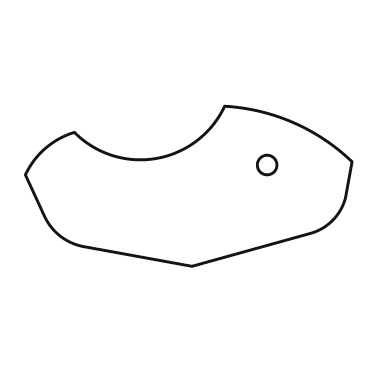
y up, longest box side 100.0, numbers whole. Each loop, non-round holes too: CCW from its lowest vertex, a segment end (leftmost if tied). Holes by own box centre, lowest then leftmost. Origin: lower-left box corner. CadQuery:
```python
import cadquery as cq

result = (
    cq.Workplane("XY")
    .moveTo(51.0, 0.0)
    .lineTo(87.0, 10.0)
    .threePointArc((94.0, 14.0), (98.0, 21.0))
    .lineTo(100.0, 32.0)
    .threePointArc((82.0, 44.0), (61.0, 49.0))
    .threePointArc((40.0, 33.0), (15.0, 41.0))
    .threePointArc((6.0, 36.0), (0.0, 28.0))
    .lineTo(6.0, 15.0)
    .threePointArc((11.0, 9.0), (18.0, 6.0))
    .close()
    .moveTo(74.0, 31.0)
    .circle(3.0)
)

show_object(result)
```